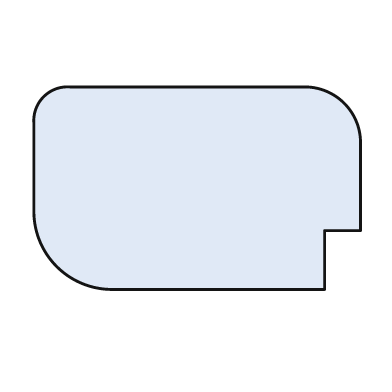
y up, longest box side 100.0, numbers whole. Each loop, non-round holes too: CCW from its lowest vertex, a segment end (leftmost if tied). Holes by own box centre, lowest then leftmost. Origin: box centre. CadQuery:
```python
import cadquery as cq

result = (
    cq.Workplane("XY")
    .moveTo(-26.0, -31.0)
    .lineTo(39.0, -31.0)
    .lineTo(39.0, -13.0)
    .lineTo(50.0, -13.0)
    .lineTo(50.0, 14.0)
    .threePointArc((45.0, 26.0), (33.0, 31.0))
    .lineTo(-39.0, 31.0)
    .threePointArc((-47.0, 28.0), (-50.0, 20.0))
    .lineTo(-50.0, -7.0)
    .threePointArc((-43.0, -24.0), (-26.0, -31.0))
    .close()
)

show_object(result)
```